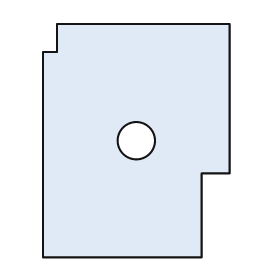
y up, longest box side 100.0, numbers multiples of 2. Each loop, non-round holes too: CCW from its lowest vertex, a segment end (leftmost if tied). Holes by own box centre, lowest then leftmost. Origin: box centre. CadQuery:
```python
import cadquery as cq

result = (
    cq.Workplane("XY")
    .moveTo(-40.0, -50.0)
    .lineTo(28.0, -50.0)
    .lineTo(28.0, -14.0)
    .lineTo(40.0, -14.0)
    .lineTo(40.0, 50.0)
    .lineTo(-34.0, 50.0)
    .lineTo(-34.0, 38.0)
    .lineTo(-40.0, 38.0)
    .close()
    .moveTo(0.0, 0.0)
    .circle(8.0)
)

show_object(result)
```